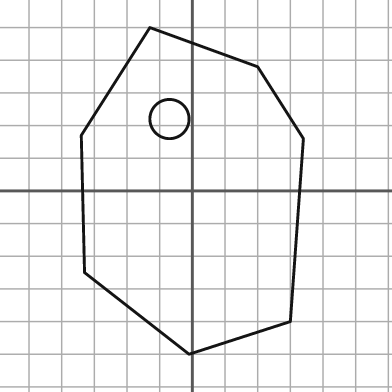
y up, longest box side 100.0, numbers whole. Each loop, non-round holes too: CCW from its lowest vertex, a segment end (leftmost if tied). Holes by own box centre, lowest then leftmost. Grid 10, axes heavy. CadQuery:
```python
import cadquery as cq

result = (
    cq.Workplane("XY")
    .moveTo(-1.0, -50.0)
    .lineTo(30.0, -40.0)
    .lineTo(34.0, 16.0)
    .lineTo(20.0, 38.0)
    .lineTo(-13.0, 50.0)
    .lineTo(-34.0, 17.0)
    .lineTo(-33.0, -25.0)
    .close()
    .moveTo(-7.0, 22.0)
    .circle(6.0)
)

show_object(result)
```